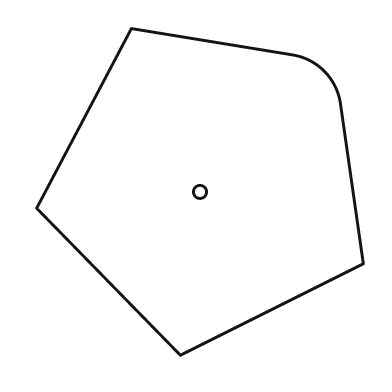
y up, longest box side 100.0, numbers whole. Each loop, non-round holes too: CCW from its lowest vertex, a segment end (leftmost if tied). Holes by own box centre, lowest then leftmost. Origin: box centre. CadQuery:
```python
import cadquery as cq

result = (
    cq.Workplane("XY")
    .moveTo(-6.0, -50.0)
    .lineTo(50.0, -22.0)
    .lineTo(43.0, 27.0)
    .threePointArc((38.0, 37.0), (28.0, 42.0))
    .lineTo(-21.0, 50.0)
    .lineTo(-50.0, -5.0)
    .close()
    .moveTo(0.0, 0.0)
    .circle(2.0)
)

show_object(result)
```